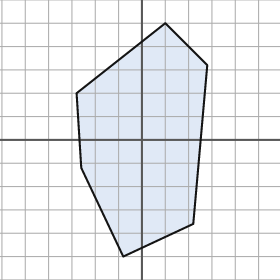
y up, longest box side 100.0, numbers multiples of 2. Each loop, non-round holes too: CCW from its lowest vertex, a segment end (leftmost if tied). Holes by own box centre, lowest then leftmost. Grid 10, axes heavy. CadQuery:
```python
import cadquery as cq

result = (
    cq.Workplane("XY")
    .moveTo(-8.0, -50.0)
    .lineTo(22.0, -36.0)
    .lineTo(28.0, 32.0)
    .lineTo(10.0, 50.0)
    .lineTo(-28.0, 20.0)
    .lineTo(-26.0, -12.0)
    .close()
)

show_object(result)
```